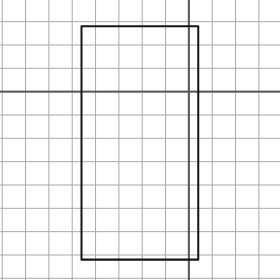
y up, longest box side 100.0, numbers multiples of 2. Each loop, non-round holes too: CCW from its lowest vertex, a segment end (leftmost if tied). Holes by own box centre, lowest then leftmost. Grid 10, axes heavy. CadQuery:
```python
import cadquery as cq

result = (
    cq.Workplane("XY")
    .moveTo(-46.0, -72.0)
    .lineTo(4.0, -72.0)
    .lineTo(4.0, 28.0)
    .lineTo(-46.0, 28.0)
    .close()
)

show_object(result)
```